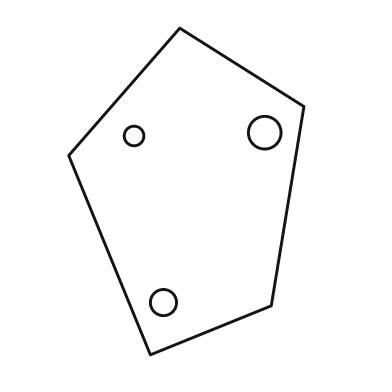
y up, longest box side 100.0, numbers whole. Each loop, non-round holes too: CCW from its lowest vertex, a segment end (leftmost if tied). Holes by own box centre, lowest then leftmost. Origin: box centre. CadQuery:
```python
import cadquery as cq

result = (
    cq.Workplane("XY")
    .moveTo(-11.0, -50.0)
    .lineTo(26.0, -35.0)
    .lineTo(36.0, 26.0)
    .lineTo(-2.0, 50.0)
    .lineTo(-36.0, 11.0)
    .close()
    .moveTo(-7.0, -34.0)
    .circle(4.0)
    .moveTo(-16.0, 17.0)
    .circle(3.0)
    .moveTo(24.0, 18.0)
    .circle(5.0)
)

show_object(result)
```